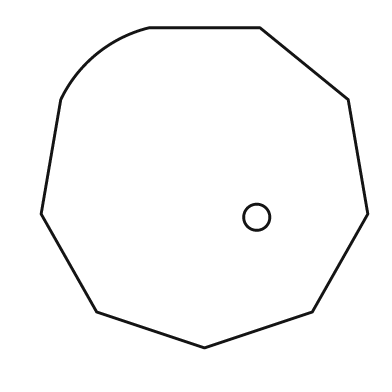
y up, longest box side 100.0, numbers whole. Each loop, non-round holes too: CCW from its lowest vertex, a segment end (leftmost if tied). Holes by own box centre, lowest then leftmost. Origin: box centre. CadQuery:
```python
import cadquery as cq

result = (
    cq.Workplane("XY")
    .moveTo(0.0, -49.0)
    .lineTo(33.0, -38.0)
    .lineTo(50.0, -8.0)
    .lineTo(44.0, 27.0)
    .lineTo(17.0, 49.0)
    .lineTo(-17.0, 49.0)
    .threePointArc((-33.0, 41.0), (-44.0, 27.0))
    .lineTo(-50.0, -8.0)
    .lineTo(-33.0, -38.0)
    .close()
    .moveTo(16.0, -9.0)
    .circle(4.0)
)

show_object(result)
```